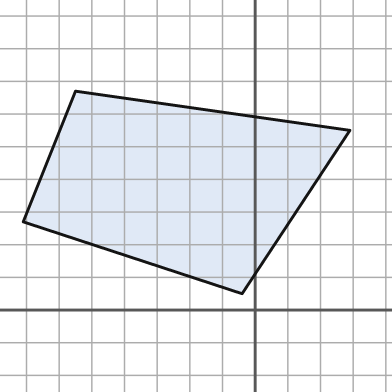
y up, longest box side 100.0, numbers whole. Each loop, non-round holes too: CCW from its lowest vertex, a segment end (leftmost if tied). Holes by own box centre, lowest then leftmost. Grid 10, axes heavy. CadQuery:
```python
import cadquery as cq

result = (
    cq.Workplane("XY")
    .moveTo(-4.0, 5.0)
    .lineTo(29.0, 55.0)
    .lineTo(-55.0, 67.0)
    .lineTo(-71.0, 27.0)
    .close()
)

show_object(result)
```